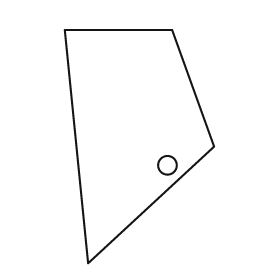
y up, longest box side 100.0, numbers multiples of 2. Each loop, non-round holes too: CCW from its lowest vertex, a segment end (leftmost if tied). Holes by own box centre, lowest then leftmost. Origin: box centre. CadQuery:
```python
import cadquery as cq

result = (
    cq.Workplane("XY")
    .moveTo(-22.0, -50.0)
    .lineTo(32.0, 0.0)
    .lineTo(14.0, 50.0)
    .lineTo(-32.0, 50.0)
    .close()
    .moveTo(12.0, -8.0)
    .circle(4.0)
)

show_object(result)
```